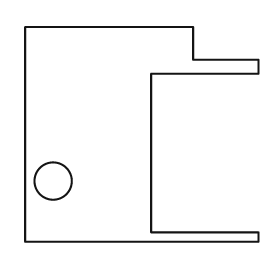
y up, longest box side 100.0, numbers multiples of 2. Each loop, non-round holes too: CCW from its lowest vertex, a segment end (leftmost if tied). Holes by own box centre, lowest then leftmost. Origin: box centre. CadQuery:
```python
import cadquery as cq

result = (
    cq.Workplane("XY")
    .moveTo(-50.0, -46.0)
    .lineTo(50.0, -46.0)
    .lineTo(50.0, -42.0)
    .lineTo(4.0, -42.0)
    .lineTo(4.0, 26.0)
    .lineTo(50.0, 26.0)
    .lineTo(50.0, 32.0)
    .lineTo(22.0, 32.0)
    .lineTo(22.0, 46.0)
    .lineTo(-50.0, 46.0)
    .close()
    .moveTo(-38.0, -20.0)
    .circle(8.0)
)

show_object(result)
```